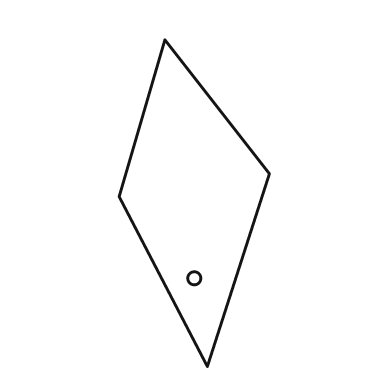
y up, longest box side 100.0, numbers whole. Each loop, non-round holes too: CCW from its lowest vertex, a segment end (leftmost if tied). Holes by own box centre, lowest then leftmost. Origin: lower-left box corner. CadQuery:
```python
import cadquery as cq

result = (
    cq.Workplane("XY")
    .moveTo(27.0, 0.0)
    .lineTo(46.0, 59.0)
    .lineTo(14.0, 100.0)
    .lineTo(0.0, 52.0)
    .close()
    .moveTo(23.0, 27.0)
    .circle(2.0)
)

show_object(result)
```